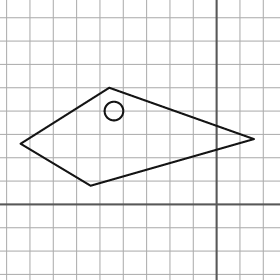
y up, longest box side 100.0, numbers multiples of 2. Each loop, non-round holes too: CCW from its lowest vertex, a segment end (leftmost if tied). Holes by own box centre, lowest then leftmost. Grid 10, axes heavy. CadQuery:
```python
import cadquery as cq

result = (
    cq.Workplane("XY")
    .moveTo(-54.0, 8.0)
    .lineTo(16.0, 28.0)
    .lineTo(-46.0, 50.0)
    .lineTo(-84.0, 26.0)
    .close()
    .moveTo(-44.0, 40.0)
    .circle(4.0)
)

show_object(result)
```